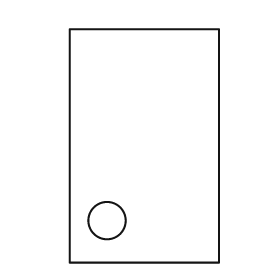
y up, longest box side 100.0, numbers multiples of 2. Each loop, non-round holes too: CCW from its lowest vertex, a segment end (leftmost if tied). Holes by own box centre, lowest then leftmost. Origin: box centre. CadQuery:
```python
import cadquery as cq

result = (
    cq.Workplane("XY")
    .moveTo(-32.0, -50.0)
    .lineTo(32.0, -50.0)
    .lineTo(32.0, 50.0)
    .lineTo(-32.0, 50.0)
    .close()
    .moveTo(-16.0, -32.0)
    .circle(8.0)
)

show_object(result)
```